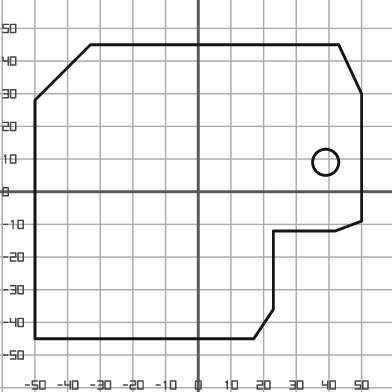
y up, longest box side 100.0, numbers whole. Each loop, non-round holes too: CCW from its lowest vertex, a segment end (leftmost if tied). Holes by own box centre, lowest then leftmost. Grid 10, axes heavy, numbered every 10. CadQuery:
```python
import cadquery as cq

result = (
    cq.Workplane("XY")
    .moveTo(-50.0, -45.0)
    .lineTo(17.0, -45.0)
    .lineTo(23.0, -36.0)
    .lineTo(23.0, -12.0)
    .lineTo(42.0, -12.0)
    .lineTo(50.0, -9.0)
    .lineTo(50.0, 30.0)
    .lineTo(43.0, 45.0)
    .lineTo(-33.0, 45.0)
    .lineTo(-50.0, 28.0)
    .close()
    .moveTo(39.0, 9.0)
    .circle(4.0)
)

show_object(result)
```